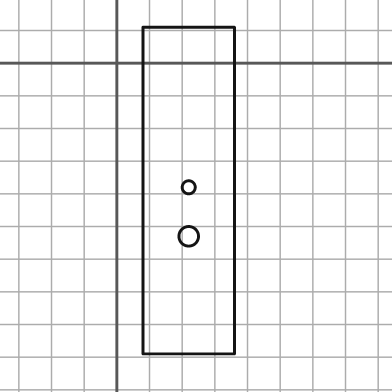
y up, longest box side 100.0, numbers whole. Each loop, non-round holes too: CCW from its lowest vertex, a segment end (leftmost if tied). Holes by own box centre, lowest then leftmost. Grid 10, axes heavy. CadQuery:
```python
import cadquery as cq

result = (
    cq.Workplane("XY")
    .moveTo(8.0, -89.0)
    .lineTo(36.0, -89.0)
    .lineTo(36.0, 11.0)
    .lineTo(8.0, 11.0)
    .close()
    .moveTo(22.0, -53.0)
    .circle(3.0)
    .moveTo(22.0, -38.0)
    .circle(2.0)
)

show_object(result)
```